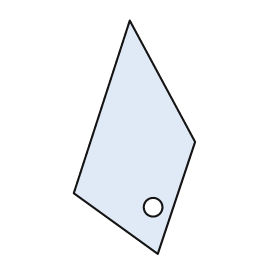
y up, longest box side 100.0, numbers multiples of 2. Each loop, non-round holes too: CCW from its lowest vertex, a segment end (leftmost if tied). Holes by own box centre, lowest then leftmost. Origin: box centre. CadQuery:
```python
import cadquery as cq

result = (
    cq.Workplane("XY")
    .moveTo(10.0, -50.0)
    .lineTo(26.0, -2.0)
    .lineTo(-2.0, 50.0)
    .lineTo(-26.0, -24.0)
    .close()
    .moveTo(8.0, -30.0)
    .circle(4.0)
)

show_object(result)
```